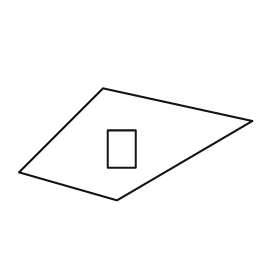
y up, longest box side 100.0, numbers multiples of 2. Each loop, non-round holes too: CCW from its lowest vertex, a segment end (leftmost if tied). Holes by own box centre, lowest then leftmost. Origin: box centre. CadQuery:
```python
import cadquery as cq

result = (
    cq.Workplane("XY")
    .moveTo(-8.0, -24.0)
    .lineTo(50.0, 10.0)
    .lineTo(-14.0, 24.0)
    .lineTo(-50.0, -12.0)
    .close()
    .moveTo(-12.0, -10.0)
    .lineTo(0.0, -10.0)
    .lineTo(0.0, 6.0)
    .lineTo(-12.0, 6.0)
    .close()
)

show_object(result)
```